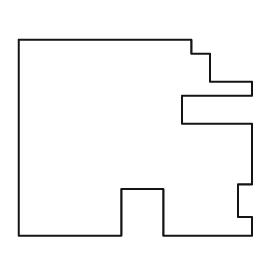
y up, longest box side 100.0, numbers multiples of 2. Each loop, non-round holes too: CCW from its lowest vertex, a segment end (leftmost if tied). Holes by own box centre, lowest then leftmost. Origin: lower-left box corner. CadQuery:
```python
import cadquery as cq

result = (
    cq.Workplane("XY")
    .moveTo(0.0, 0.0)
    .lineTo(44.0, 0.0)
    .lineTo(44.0, 20.0)
    .lineTo(62.0, 20.0)
    .lineTo(62.0, 0.0)
    .lineTo(100.0, 0.0)
    .lineTo(100.0, 8.0)
    .lineTo(94.0, 8.0)
    .lineTo(94.0, 22.0)
    .lineTo(100.0, 22.0)
    .lineTo(100.0, 48.0)
    .lineTo(70.0, 48.0)
    .lineTo(70.0, 60.0)
    .lineTo(100.0, 60.0)
    .lineTo(100.0, 66.0)
    .lineTo(82.0, 66.0)
    .lineTo(82.0, 78.0)
    .lineTo(74.0, 78.0)
    .lineTo(74.0, 84.0)
    .lineTo(0.0, 84.0)
    .close()
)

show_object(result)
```